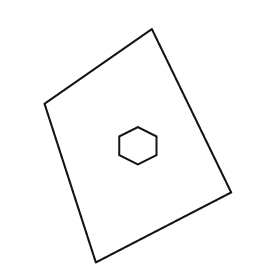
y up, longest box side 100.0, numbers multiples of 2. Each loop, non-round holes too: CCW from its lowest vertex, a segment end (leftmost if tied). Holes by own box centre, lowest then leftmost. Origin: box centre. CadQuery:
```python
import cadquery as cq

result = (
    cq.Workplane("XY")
    .moveTo(-18.0, -50.0)
    .lineTo(40.0, -20.0)
    .lineTo(6.0, 50.0)
    .lineTo(-40.0, 18.0)
    .close()
    .moveTo(0.0, -8.0)
    .lineTo(8.0, -4.0)
    .lineTo(8.0, 4.0)
    .lineTo(0.0, 8.0)
    .lineTo(-8.0, 4.0)
    .lineTo(-8.0, -4.0)
    .close()
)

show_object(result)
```